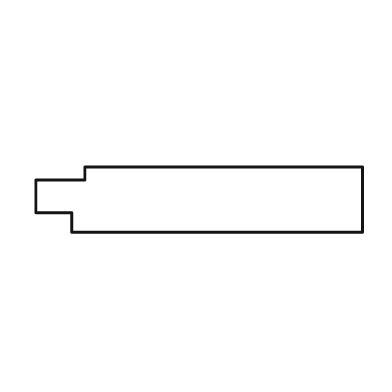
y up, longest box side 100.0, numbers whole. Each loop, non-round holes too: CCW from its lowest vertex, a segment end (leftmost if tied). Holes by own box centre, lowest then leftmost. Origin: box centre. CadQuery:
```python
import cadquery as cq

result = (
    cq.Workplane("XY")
    .moveTo(-39.0, -10.0)
    .lineTo(50.0, -10.0)
    .lineTo(50.0, 10.0)
    .lineTo(-35.0, 10.0)
    .lineTo(-35.0, 6.0)
    .lineTo(-50.0, 6.0)
    .lineTo(-50.0, -4.0)
    .lineTo(-39.0, -4.0)
    .close()
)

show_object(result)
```